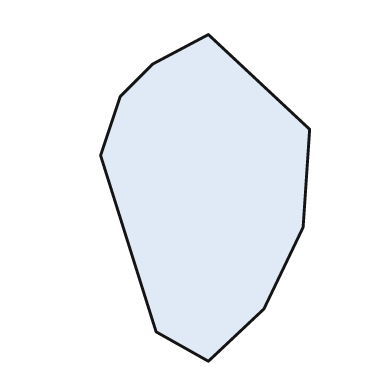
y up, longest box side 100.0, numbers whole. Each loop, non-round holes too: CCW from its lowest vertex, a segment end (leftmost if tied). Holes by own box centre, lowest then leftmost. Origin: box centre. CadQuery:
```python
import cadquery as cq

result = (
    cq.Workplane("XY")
    .moveTo(1.0, -50.0)
    .lineTo(18.0, -34.0)
    .lineTo(30.0, -9.0)
    .lineTo(32.0, 21.0)
    .lineTo(1.0, 50.0)
    .lineTo(-16.0, 41.0)
    .lineTo(-26.0, 31.0)
    .lineTo(-32.0, 13.0)
    .lineTo(-15.0, -41.0)
    .close()
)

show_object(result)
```